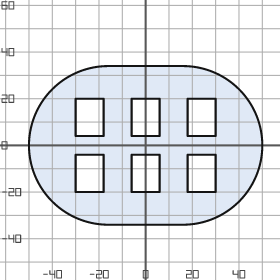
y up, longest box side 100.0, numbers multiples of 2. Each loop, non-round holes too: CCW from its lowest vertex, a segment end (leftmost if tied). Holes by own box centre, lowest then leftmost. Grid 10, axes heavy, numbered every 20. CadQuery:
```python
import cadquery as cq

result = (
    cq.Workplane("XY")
    .moveTo(-16.0, -34.0)
    .lineTo(16.0, -34.0)
    .threePointArc((50.0, 0.0), (16.0, 34.0))
    .lineTo(-16.0, 34.0)
    .threePointArc((-50.0, 0.0), (-16.0, -34.0))
    .close()
    .moveTo(-30.0, -20.0)
    .lineTo(-18.0, -20.0)
    .lineTo(-18.0, -4.0)
    .lineTo(-30.0, -4.0)
    .close()
    .moveTo(-6.0, -20.0)
    .lineTo(6.0, -20.0)
    .lineTo(6.0, -4.0)
    .lineTo(-6.0, -4.0)
    .close()
    .moveTo(18.0, -20.0)
    .lineTo(30.0, -20.0)
    .lineTo(30.0, -4.0)
    .lineTo(18.0, -4.0)
    .close()
    .moveTo(-30.0, 4.0)
    .lineTo(-18.0, 4.0)
    .lineTo(-18.0, 20.0)
    .lineTo(-30.0, 20.0)
    .close()
    .moveTo(-6.0, 4.0)
    .lineTo(6.0, 4.0)
    .lineTo(6.0, 20.0)
    .lineTo(-6.0, 20.0)
    .close()
    .moveTo(18.0, 4.0)
    .lineTo(30.0, 4.0)
    .lineTo(30.0, 20.0)
    .lineTo(18.0, 20.0)
    .close()
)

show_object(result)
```